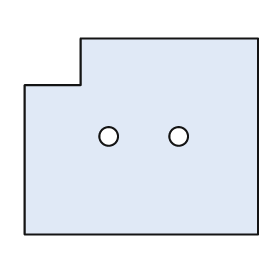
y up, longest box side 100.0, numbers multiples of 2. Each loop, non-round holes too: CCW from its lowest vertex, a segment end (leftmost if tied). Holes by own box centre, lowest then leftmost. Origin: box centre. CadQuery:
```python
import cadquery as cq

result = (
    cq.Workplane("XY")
    .moveTo(-50.0, -42.0)
    .lineTo(50.0, -42.0)
    .lineTo(50.0, 42.0)
    .lineTo(-26.0, 42.0)
    .lineTo(-26.0, 22.0)
    .lineTo(-50.0, 22.0)
    .close()
    .moveTo(-14.0, 0.0)
    .circle(4.0)
    .moveTo(16.0, 0.0)
    .circle(4.0)
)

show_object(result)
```